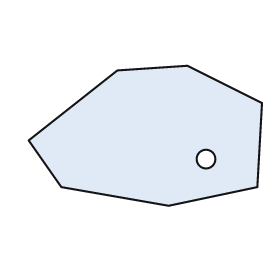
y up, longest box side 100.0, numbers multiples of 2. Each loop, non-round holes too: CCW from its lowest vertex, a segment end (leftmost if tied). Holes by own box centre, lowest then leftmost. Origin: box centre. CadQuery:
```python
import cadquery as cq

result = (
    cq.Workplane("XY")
    .moveTo(10.0, -30.0)
    .lineTo(48.0, -22.0)
    .lineTo(50.0, 14.0)
    .lineTo(18.0, 30.0)
    .lineTo(-12.0, 28.0)
    .lineTo(-50.0, -2.0)
    .lineTo(-36.0, -22.0)
    .close()
    .moveTo(26.0, -10.0)
    .circle(4.0)
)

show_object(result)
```